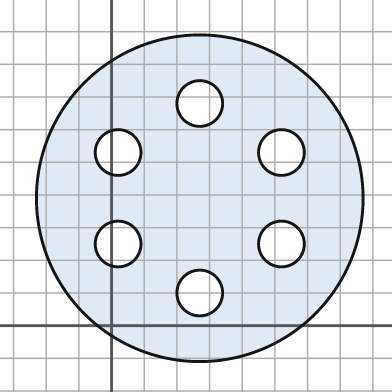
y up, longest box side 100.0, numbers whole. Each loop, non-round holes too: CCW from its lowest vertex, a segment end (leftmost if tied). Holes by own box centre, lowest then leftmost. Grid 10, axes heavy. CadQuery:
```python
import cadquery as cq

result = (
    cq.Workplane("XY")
    .moveTo(27.0, 39.0)
    .circle(50.0)
    .moveTo(27.0, 10.0)
    .circle(7.0)
    .moveTo(2.0, 25.0)
    .circle(7.0)
    .moveTo(52.0, 25.0)
    .circle(7.0)
    .moveTo(2.0, 53.0)
    .circle(7.0)
    .moveTo(52.0, 53.0)
    .circle(7.0)
    .moveTo(27.0, 68.0)
    .circle(7.0)
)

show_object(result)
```